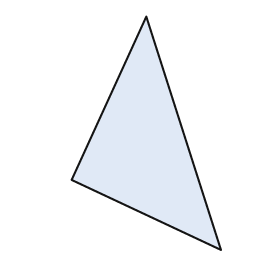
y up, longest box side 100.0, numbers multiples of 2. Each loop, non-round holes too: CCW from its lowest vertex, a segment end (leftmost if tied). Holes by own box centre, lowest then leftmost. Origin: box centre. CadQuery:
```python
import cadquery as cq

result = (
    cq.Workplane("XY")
    .moveTo(32.0, -50.0)
    .lineTo(0.0, 50.0)
    .lineTo(-32.0, -20.0)
    .close()
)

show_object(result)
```